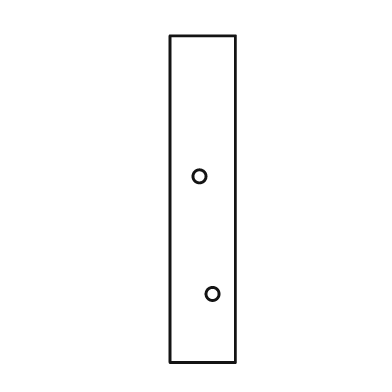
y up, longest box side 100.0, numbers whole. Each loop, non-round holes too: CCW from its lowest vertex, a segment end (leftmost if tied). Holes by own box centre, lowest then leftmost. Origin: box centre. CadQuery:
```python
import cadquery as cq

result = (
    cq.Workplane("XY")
    .moveTo(-10.0, -50.0)
    .lineTo(10.0, -50.0)
    .lineTo(10.0, 50.0)
    .lineTo(-10.0, 50.0)
    .close()
    .moveTo(3.0, -29.0)
    .circle(2.0)
    .moveTo(-1.0, 7.0)
    .circle(2.0)
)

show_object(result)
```